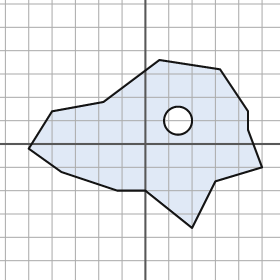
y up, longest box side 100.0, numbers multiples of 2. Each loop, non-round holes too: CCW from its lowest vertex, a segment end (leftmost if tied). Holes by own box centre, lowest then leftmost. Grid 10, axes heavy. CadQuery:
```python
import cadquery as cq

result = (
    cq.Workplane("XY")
    .moveTo(20.0, -36.0)
    .lineTo(30.0, -16.0)
    .lineTo(50.0, -10.0)
    .lineTo(44.0, 6.0)
    .lineTo(44.0, 14.0)
    .lineTo(32.0, 32.0)
    .lineTo(6.0, 36.0)
    .lineTo(-18.0, 18.0)
    .lineTo(-40.0, 14.0)
    .lineTo(-50.0, -2.0)
    .lineTo(-36.0, -12.0)
    .lineTo(-12.0, -20.0)
    .lineTo(0.0, -20.0)
    .close()
    .moveTo(14.0, 10.0)
    .circle(6.0)
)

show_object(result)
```